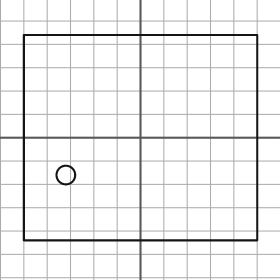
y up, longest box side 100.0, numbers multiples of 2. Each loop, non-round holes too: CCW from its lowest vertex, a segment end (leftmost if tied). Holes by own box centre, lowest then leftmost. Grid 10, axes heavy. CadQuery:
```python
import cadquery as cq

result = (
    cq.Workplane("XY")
    .moveTo(-50.0, -44.0)
    .lineTo(50.0, -44.0)
    .lineTo(50.0, 44.0)
    .lineTo(-50.0, 44.0)
    .close()
    .moveTo(-32.0, -16.0)
    .circle(4.0)
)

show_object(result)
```